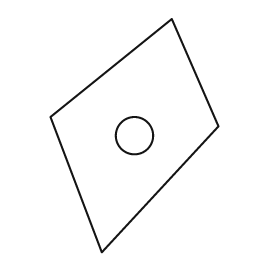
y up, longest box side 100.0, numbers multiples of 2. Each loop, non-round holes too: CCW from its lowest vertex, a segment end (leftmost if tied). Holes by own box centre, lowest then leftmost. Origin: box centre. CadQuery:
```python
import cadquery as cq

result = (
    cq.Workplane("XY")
    .moveTo(-14.0, -50.0)
    .lineTo(36.0, 4.0)
    .lineTo(16.0, 50.0)
    .lineTo(-36.0, 8.0)
    .close()
    .moveTo(0.0, 0.0)
    .circle(8.0)
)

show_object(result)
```